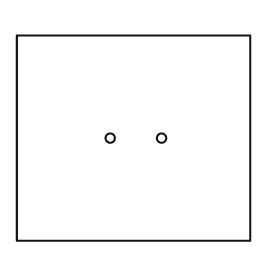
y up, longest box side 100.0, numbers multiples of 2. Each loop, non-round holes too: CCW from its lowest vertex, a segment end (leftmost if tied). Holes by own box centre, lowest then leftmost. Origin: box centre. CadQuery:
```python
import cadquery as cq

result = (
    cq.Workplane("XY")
    .moveTo(-50.0, -44.0)
    .lineTo(50.0, -44.0)
    .lineTo(50.0, 44.0)
    .lineTo(-50.0, 44.0)
    .close()
    .moveTo(-10.0, 0.0)
    .circle(2.0)
    .moveTo(12.0, 0.0)
    .circle(2.0)
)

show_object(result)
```